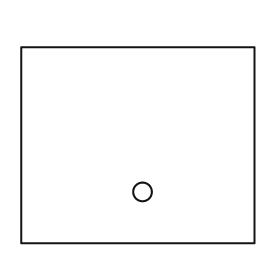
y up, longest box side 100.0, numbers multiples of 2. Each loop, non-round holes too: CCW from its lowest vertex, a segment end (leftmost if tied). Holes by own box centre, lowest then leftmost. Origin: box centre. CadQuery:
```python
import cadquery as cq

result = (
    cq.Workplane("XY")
    .moveTo(-50.0, -42.0)
    .lineTo(50.0, -42.0)
    .lineTo(50.0, 42.0)
    .lineTo(-50.0, 42.0)
    .close()
    .moveTo(2.0, -20.0)
    .circle(4.0)
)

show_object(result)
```